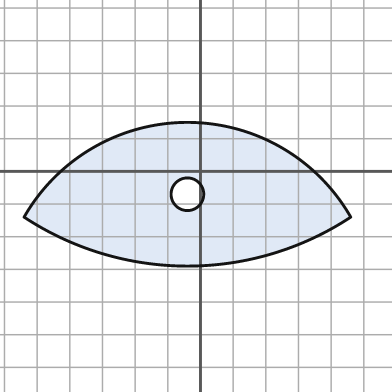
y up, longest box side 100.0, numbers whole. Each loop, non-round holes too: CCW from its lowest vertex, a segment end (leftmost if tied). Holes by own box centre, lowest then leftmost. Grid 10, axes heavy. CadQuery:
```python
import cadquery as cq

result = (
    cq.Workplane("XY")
    .moveTo(-54.0, -14.0)
    .threePointArc((-4.0, -29.0), (46.0, -14.0))
    .threePointArc((-4.0, 15.0), (-54.0, -14.0))
    .close()
    .moveTo(-4.0, -7.0)
    .circle(5.0)
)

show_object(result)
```